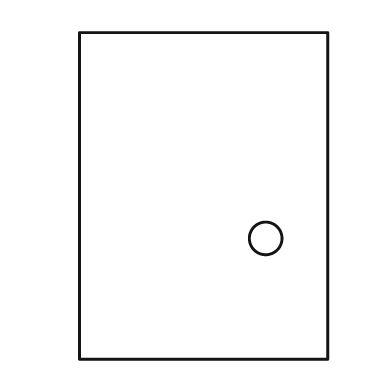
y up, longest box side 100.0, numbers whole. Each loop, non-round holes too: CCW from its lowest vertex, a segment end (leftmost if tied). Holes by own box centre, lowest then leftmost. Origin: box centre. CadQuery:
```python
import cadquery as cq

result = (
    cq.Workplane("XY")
    .moveTo(-38.0, -50.0)
    .lineTo(38.0, -50.0)
    .lineTo(38.0, 50.0)
    .lineTo(-38.0, 50.0)
    .close()
    .moveTo(19.0, -13.0)
    .circle(5.0)
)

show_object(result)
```